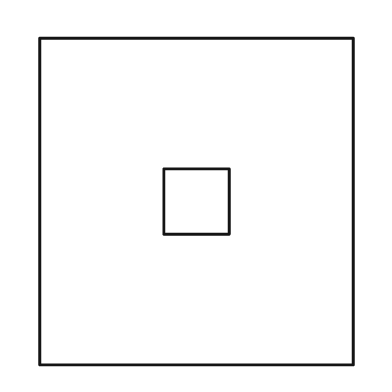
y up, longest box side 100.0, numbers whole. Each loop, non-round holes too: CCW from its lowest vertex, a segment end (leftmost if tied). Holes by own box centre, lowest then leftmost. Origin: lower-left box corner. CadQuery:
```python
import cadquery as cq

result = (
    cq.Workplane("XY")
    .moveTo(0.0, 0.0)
    .lineTo(96.0, 0.0)
    .lineTo(96.0, 100.0)
    .lineTo(0.0, 100.0)
    .close()
    .moveTo(38.0, 40.0)
    .lineTo(58.0, 40.0)
    .lineTo(58.0, 60.0)
    .lineTo(38.0, 60.0)
    .close()
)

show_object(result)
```